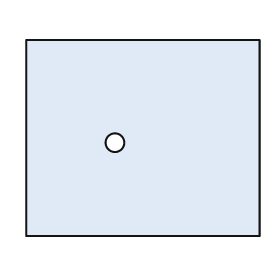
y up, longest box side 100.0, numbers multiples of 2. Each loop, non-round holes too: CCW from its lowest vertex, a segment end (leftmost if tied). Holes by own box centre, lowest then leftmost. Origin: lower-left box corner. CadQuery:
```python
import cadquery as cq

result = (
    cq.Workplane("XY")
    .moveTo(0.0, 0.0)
    .lineTo(100.0, 0.0)
    .lineTo(100.0, 84.0)
    .lineTo(0.0, 84.0)
    .close()
    .moveTo(38.0, 40.0)
    .circle(4.0)
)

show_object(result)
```